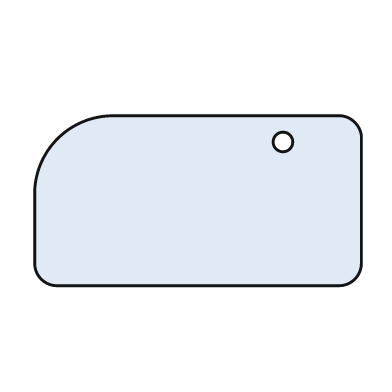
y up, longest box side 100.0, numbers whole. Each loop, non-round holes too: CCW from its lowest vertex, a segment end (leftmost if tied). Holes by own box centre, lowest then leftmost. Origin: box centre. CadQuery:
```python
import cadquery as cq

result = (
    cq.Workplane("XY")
    .moveTo(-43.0, -26.0)
    .lineTo(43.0, -26.0)
    .threePointArc((48.0, -24.0), (50.0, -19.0))
    .lineTo(50.0, 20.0)
    .threePointArc((48.0, 24.0), (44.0, 26.0))
    .lineTo(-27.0, 26.0)
    .threePointArc((-43.0, 19.0), (-50.0, 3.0))
    .lineTo(-50.0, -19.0)
    .threePointArc((-48.0, -24.0), (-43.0, -26.0))
    .close()
    .moveTo(26.0, 18.0)
    .circle(3.0)
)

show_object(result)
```